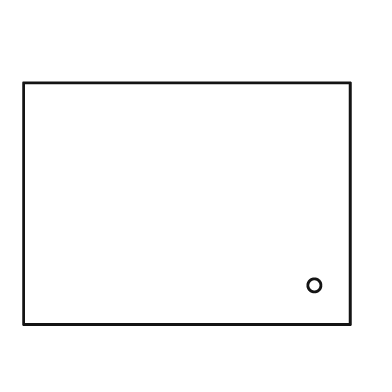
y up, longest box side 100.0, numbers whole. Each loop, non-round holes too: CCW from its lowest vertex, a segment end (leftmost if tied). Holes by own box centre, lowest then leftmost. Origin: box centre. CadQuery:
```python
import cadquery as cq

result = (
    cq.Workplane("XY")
    .moveTo(-50.0, -37.0)
    .lineTo(50.0, -37.0)
    .lineTo(50.0, 37.0)
    .lineTo(-50.0, 37.0)
    .close()
    .moveTo(39.0, -25.0)
    .circle(2.0)
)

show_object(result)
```